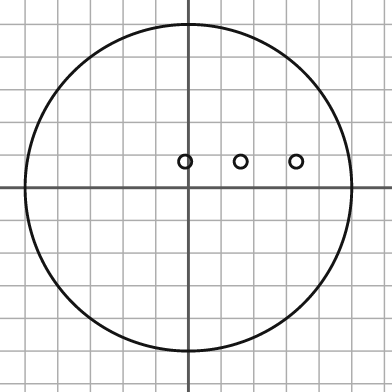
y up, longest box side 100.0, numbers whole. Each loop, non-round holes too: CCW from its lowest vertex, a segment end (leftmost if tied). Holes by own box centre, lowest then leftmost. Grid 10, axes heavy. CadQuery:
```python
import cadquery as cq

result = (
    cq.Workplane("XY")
    .moveTo(0.0, 0.0)
    .circle(50.0)
    .moveTo(-1.0, 8.0)
    .circle(2.0)
    .moveTo(16.0, 8.0)
    .circle(2.0)
    .moveTo(33.0, 8.0)
    .circle(2.0)
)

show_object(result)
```